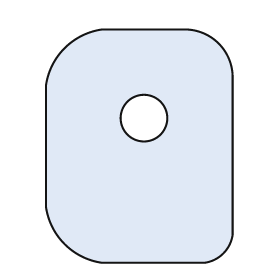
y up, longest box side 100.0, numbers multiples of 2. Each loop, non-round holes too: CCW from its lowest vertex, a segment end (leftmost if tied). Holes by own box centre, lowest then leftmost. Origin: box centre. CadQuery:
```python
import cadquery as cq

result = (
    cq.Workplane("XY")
    .moveTo(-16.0, -50.0)
    .lineTo(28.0, -50.0)
    .threePointArc((36.0, -46.0), (40.0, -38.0))
    .lineTo(40.0, 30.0)
    .threePointArc((34.0, 44.0), (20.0, 50.0))
    .lineTo(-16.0, 50.0)
    .threePointArc((-32.0, 42.0), (-40.0, 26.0))
    .lineTo(-40.0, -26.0)
    .threePointArc((-32.0, -42.0), (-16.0, -50.0))
    .close()
    .moveTo(2.0, 12.0)
    .circle(10.0)
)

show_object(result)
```